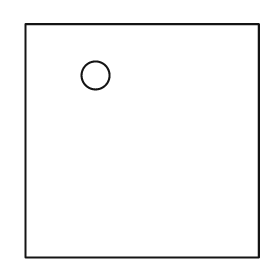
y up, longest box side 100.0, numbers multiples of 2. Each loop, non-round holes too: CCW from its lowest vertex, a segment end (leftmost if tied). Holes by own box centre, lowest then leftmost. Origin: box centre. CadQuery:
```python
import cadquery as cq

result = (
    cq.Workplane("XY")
    .moveTo(-50.0, -50.0)
    .lineTo(50.0, -50.0)
    .lineTo(50.0, 50.0)
    .lineTo(-50.0, 50.0)
    .close()
    .moveTo(-20.0, 28.0)
    .circle(6.0)
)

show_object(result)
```